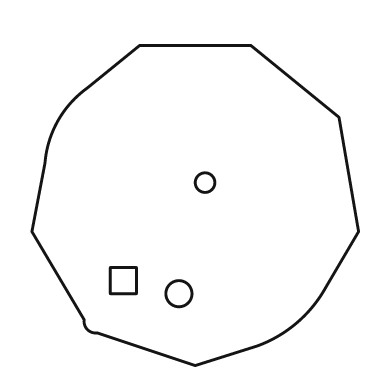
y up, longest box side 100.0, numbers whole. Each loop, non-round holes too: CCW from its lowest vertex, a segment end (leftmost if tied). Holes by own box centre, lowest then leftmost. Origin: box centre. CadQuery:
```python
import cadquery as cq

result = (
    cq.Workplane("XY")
    .moveTo(0.0, -49.0)
    .lineTo(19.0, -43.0)
    .threePointArc((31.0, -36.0), (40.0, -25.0))
    .lineTo(50.0, -8.0)
    .lineTo(44.0, 27.0)
    .lineTo(17.0, 49.0)
    .lineTo(-17.0, 49.0)
    .lineTo(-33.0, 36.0)
    .threePointArc((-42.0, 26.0), (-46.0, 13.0))
    .lineTo(-50.0, -8.0)
    .lineTo(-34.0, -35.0)
    .threePointArc((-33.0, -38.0), (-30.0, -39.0))
    .close()
    .moveTo(-5.0, -27.0)
    .circle(4.0)
    .moveTo(-26.0, -27.0)
    .lineTo(-18.0, -27.0)
    .lineTo(-18.0, -19.0)
    .lineTo(-26.0, -19.0)
    .close()
    .moveTo(3.0, 7.0)
    .circle(3.0)
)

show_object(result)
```